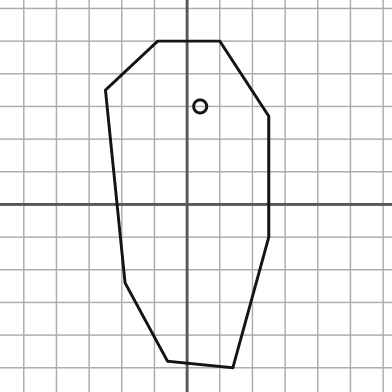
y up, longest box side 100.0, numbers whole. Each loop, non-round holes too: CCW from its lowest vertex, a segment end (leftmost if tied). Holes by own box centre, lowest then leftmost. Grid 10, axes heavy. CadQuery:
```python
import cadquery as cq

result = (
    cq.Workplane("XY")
    .moveTo(14.0, -50.0)
    .lineTo(25.0, -10.0)
    .lineTo(25.0, 27.0)
    .lineTo(10.0, 50.0)
    .lineTo(-9.0, 50.0)
    .lineTo(-25.0, 35.0)
    .lineTo(-19.0, -24.0)
    .lineTo(-6.0, -48.0)
    .close()
    .moveTo(4.0, 30.0)
    .circle(2.0)
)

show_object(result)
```